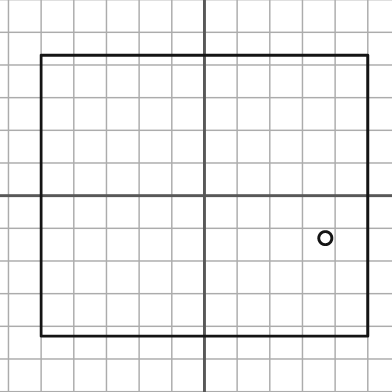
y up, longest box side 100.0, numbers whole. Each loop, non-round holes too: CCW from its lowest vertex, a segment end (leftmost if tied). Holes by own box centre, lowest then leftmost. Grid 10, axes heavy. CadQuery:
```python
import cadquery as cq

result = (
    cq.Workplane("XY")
    .moveTo(-50.0, -43.0)
    .lineTo(50.0, -43.0)
    .lineTo(50.0, 43.0)
    .lineTo(-50.0, 43.0)
    .close()
    .moveTo(37.0, -13.0)
    .circle(2.0)
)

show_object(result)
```